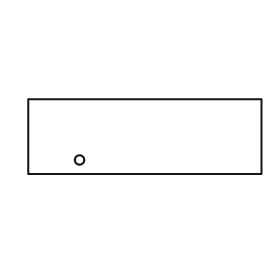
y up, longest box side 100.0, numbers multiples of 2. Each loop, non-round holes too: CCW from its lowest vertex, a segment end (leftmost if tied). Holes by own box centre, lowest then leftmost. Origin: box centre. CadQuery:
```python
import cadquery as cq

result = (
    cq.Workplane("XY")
    .moveTo(-50.0, -16.0)
    .lineTo(50.0, -16.0)
    .lineTo(50.0, 16.0)
    .lineTo(-50.0, 16.0)
    .close()
    .moveTo(-28.0, -10.0)
    .circle(2.0)
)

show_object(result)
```